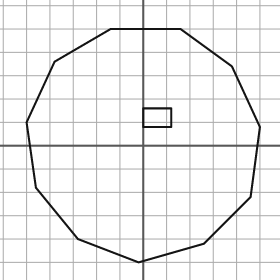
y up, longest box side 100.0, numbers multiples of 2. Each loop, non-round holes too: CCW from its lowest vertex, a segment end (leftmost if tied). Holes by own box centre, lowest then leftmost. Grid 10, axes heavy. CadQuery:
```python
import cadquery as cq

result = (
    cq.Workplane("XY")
    .moveTo(-2.0, -50.0)
    .lineTo(26.0, -42.0)
    .lineTo(46.0, -22.0)
    .lineTo(50.0, 8.0)
    .lineTo(38.0, 34.0)
    .lineTo(16.0, 50.0)
    .lineTo(-14.0, 50.0)
    .lineTo(-38.0, 36.0)
    .lineTo(-50.0, 10.0)
    .lineTo(-46.0, -18.0)
    .lineTo(-28.0, -40.0)
    .close()
    .moveTo(0.0, 8.0)
    .lineTo(12.0, 8.0)
    .lineTo(12.0, 16.0)
    .lineTo(0.0, 16.0)
    .close()
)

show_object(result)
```